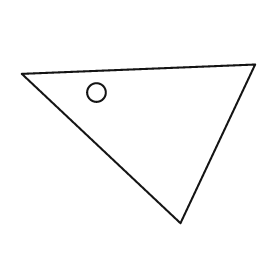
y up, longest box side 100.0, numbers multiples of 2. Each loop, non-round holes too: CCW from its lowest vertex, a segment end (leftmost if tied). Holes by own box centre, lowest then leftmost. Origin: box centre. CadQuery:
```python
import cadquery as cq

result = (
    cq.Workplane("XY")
    .moveTo(18.0, -34.0)
    .lineTo(50.0, 34.0)
    .lineTo(-50.0, 30.0)
    .close()
    .moveTo(-18.0, 22.0)
    .circle(4.0)
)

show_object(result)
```